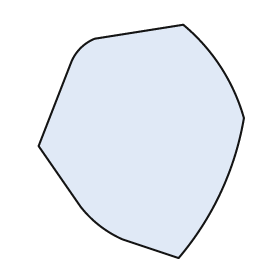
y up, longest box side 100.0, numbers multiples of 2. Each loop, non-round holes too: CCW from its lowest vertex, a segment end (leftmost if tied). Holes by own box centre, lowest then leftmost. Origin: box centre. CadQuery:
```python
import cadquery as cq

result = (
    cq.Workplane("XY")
    .moveTo(16.0, -50.0)
    .threePointArc((34.0, -22.0), (44.0, 10.0))
    .threePointArc((34.0, 32.0), (18.0, 50.0))
    .lineTo(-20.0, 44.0)
    .threePointArc((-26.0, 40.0), (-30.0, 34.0))
    .lineTo(-44.0, -2.0)
    .lineTo(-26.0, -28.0)
    .threePointArc((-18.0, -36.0), (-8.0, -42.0))
    .close()
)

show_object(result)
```